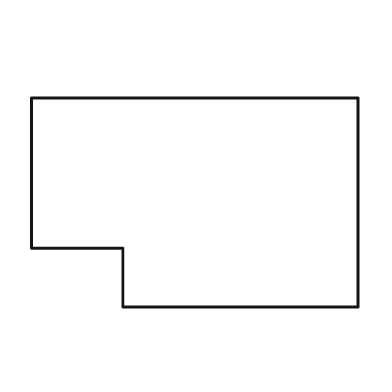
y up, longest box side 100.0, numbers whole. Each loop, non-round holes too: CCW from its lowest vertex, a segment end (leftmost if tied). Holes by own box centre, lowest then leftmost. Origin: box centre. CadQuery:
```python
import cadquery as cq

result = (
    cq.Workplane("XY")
    .moveTo(-22.0, -32.0)
    .lineTo(50.0, -32.0)
    .lineTo(50.0, 32.0)
    .lineTo(-50.0, 32.0)
    .lineTo(-50.0, -14.0)
    .lineTo(-22.0, -14.0)
    .close()
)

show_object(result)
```